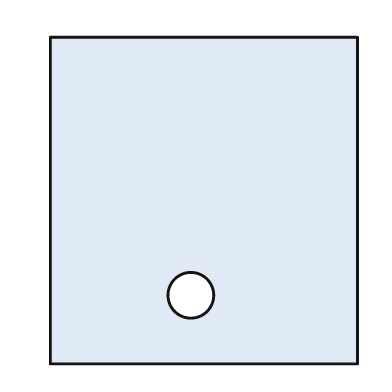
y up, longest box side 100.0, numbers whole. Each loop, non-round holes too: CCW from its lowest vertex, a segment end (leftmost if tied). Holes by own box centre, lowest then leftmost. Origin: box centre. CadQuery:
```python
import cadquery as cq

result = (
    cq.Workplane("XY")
    .moveTo(-47.0, -50.0)
    .lineTo(47.0, -50.0)
    .lineTo(47.0, 50.0)
    .lineTo(-47.0, 50.0)
    .close()
    .moveTo(-4.0, -29.0)
    .circle(7.0)
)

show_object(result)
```